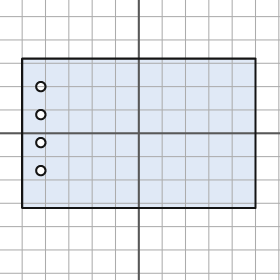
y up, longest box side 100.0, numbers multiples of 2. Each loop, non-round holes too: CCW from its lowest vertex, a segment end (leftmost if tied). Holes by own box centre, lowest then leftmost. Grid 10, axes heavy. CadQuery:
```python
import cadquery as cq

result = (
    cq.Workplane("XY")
    .moveTo(-50.0, -32.0)
    .lineTo(50.0, -32.0)
    .lineTo(50.0, 32.0)
    .lineTo(-50.0, 32.0)
    .close()
    .moveTo(-42.0, -16.0)
    .circle(2.0)
    .moveTo(-42.0, -4.0)
    .circle(2.0)
    .moveTo(-42.0, 8.0)
    .circle(2.0)
    .moveTo(-42.0, 20.0)
    .circle(2.0)
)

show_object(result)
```